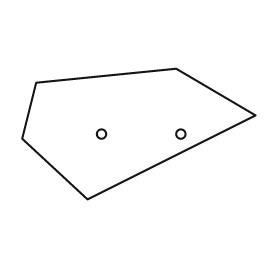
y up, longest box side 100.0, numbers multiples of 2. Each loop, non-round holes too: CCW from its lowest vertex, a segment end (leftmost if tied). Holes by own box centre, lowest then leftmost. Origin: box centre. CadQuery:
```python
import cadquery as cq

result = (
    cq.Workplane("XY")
    .moveTo(-22.0, -28.0)
    .lineTo(50.0, 8.0)
    .lineTo(16.0, 28.0)
    .lineTo(-44.0, 22.0)
    .lineTo(-50.0, -2.0)
    .close()
    .moveTo(-16.0, 0.0)
    .circle(2.0)
    .moveTo(18.0, 0.0)
    .circle(2.0)
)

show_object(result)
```